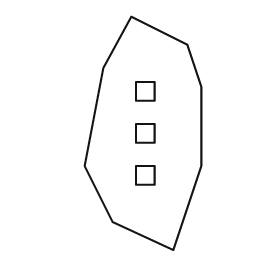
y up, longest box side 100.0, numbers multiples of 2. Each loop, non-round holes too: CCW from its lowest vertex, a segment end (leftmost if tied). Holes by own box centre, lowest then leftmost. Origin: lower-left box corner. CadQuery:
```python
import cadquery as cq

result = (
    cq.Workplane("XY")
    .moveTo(38.0, 0.0)
    .lineTo(50.0, 36.0)
    .lineTo(50.0, 70.0)
    .lineTo(44.0, 88.0)
    .lineTo(20.0, 100.0)
    .lineTo(8.0, 78.0)
    .lineTo(0.0, 36.0)
    .lineTo(12.0, 12.0)
    .close()
    .moveTo(22.0, 28.0)
    .lineTo(30.0, 28.0)
    .lineTo(30.0, 36.0)
    .lineTo(22.0, 36.0)
    .close()
    .moveTo(22.0, 46.0)
    .lineTo(30.0, 46.0)
    .lineTo(30.0, 54.0)
    .lineTo(22.0, 54.0)
    .close()
    .moveTo(22.0, 64.0)
    .lineTo(30.0, 64.0)
    .lineTo(30.0, 72.0)
    .lineTo(22.0, 72.0)
    .close()
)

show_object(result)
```